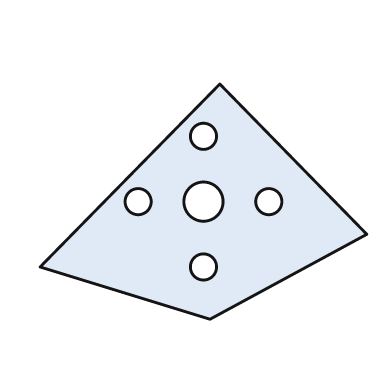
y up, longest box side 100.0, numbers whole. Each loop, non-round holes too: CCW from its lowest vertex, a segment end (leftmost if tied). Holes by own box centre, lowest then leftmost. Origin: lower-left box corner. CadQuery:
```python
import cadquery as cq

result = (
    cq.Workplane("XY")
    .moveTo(52.0, 0.0)
    .lineTo(100.0, 26.0)
    .lineTo(55.0, 72.0)
    .lineTo(0.0, 16.0)
    .close()
    .moveTo(50.0, 16.0)
    .circle(4.0)
    .moveTo(30.0, 36.0)
    .circle(4.0)
    .moveTo(50.0, 36.0)
    .circle(6.0)
    .moveTo(70.0, 36.0)
    .circle(4.0)
    .moveTo(50.0, 56.0)
    .circle(4.0)
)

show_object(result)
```